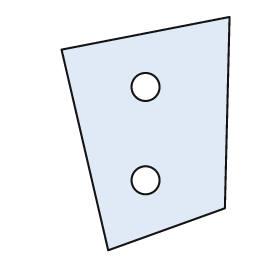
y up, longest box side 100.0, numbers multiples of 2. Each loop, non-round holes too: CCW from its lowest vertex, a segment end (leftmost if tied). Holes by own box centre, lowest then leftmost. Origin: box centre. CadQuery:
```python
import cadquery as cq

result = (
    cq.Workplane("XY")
    .moveTo(-16.0, -50.0)
    .lineTo(34.0, -32.0)
    .lineTo(36.0, 50.0)
    .lineTo(-36.0, 36.0)
    .close()
    .moveTo(0.0, -20.0)
    .circle(6.0)
    .moveTo(0.0, 20.0)
    .circle(6.0)
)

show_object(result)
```